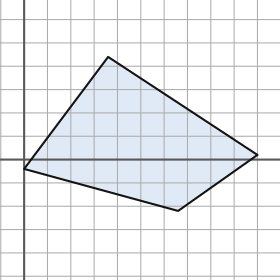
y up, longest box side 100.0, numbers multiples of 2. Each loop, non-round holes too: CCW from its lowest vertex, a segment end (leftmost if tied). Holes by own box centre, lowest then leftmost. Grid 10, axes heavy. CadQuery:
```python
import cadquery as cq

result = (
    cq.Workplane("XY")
    .moveTo(66.0, -22.0)
    .lineTo(100.0, 2.0)
    .lineTo(36.0, 44.0)
    .lineTo(0.0, -4.0)
    .close()
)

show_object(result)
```